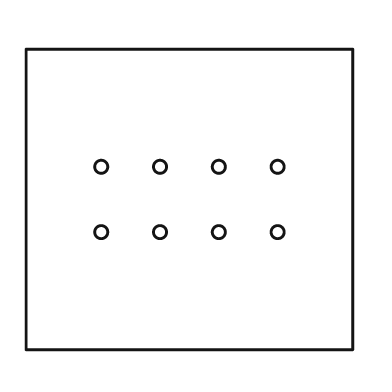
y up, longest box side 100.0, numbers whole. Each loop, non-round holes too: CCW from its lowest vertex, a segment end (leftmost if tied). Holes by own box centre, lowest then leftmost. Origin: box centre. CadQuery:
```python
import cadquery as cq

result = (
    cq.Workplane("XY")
    .moveTo(-50.0, -46.0)
    .lineTo(50.0, -46.0)
    .lineTo(50.0, 46.0)
    .lineTo(-50.0, 46.0)
    .close()
    .moveTo(-27.0, -10.0)
    .circle(2.0)
    .moveTo(-9.0, -10.0)
    .circle(2.0)
    .moveTo(9.0, -10.0)
    .circle(2.0)
    .moveTo(27.0, -10.0)
    .circle(2.0)
    .moveTo(-27.0, 10.0)
    .circle(2.0)
    .moveTo(-9.0, 10.0)
    .circle(2.0)
    .moveTo(9.0, 10.0)
    .circle(2.0)
    .moveTo(27.0, 10.0)
    .circle(2.0)
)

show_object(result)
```